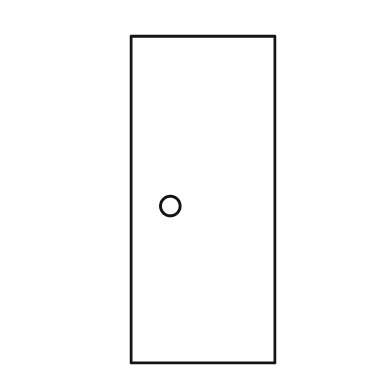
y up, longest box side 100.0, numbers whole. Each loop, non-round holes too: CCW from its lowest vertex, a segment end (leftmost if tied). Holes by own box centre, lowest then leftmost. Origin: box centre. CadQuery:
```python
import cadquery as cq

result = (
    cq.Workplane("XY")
    .moveTo(-22.0, -50.0)
    .lineTo(22.0, -50.0)
    .lineTo(22.0, 50.0)
    .lineTo(-22.0, 50.0)
    .close()
    .moveTo(-10.0, -2.0)
    .circle(3.0)
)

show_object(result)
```